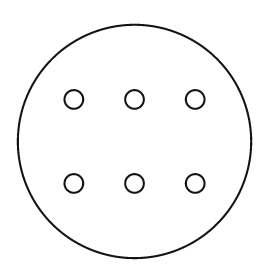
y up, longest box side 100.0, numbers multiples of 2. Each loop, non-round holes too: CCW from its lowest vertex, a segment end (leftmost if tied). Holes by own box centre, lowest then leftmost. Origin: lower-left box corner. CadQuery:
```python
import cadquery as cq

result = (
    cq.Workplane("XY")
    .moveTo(50.0, 50.0)
    .circle(50.0)
    .moveTo(24.0, 32.0)
    .circle(4.0)
    .moveTo(50.0, 32.0)
    .circle(4.0)
    .moveTo(76.0, 32.0)
    .circle(4.0)
    .moveTo(24.0, 68.0)
    .circle(4.0)
    .moveTo(50.0, 68.0)
    .circle(4.0)
    .moveTo(76.0, 68.0)
    .circle(4.0)
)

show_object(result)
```